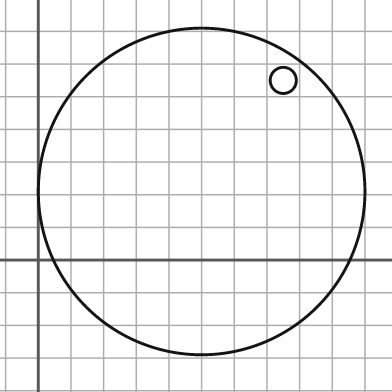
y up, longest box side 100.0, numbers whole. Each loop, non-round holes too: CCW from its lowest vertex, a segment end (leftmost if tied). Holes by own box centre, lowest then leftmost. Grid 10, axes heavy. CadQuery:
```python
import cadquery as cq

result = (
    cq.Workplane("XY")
    .moveTo(50.0, 21.0)
    .circle(50.0)
    .moveTo(75.0, 55.0)
    .circle(4.0)
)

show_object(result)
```